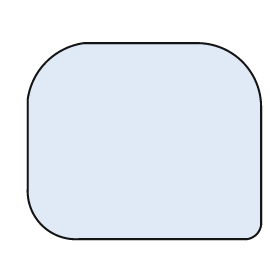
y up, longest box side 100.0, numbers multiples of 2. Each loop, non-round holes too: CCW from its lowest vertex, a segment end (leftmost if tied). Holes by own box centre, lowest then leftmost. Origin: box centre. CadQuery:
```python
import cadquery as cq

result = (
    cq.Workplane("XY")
    .moveTo(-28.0, -42.0)
    .lineTo(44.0, -42.0)
    .threePointArc((48.0, -40.0), (50.0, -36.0))
    .lineTo(50.0, 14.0)
    .threePointArc((42.0, 34.0), (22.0, 42.0))
    .lineTo(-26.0, 42.0)
    .threePointArc((-42.0, 34.0), (-50.0, 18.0))
    .lineTo(-50.0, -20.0)
    .threePointArc((-44.0, -36.0), (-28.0, -42.0))
    .close()
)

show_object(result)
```